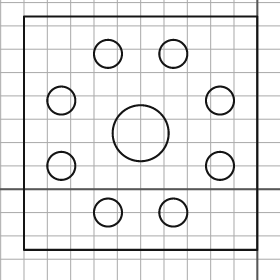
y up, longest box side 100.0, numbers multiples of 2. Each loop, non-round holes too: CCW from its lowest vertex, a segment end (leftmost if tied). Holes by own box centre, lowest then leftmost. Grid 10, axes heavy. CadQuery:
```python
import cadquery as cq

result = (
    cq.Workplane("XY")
    .moveTo(-100.0, -26.0)
    .lineTo(0.0, -26.0)
    .lineTo(0.0, 74.0)
    .lineTo(-100.0, 74.0)
    .close()
    .moveTo(-64.0, -10.0)
    .circle(6.0)
    .moveTo(-36.0, -10.0)
    .circle(6.0)
    .moveTo(-84.0, 10.0)
    .circle(6.0)
    .moveTo(-16.0, 10.0)
    .circle(6.0)
    .moveTo(-50.0, 24.0)
    .circle(12.0)
    .moveTo(-84.0, 38.0)
    .circle(6.0)
    .moveTo(-16.0, 38.0)
    .circle(6.0)
    .moveTo(-64.0, 58.0)
    .circle(6.0)
    .moveTo(-36.0, 58.0)
    .circle(6.0)
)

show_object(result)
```